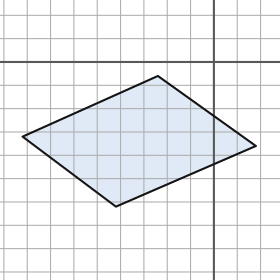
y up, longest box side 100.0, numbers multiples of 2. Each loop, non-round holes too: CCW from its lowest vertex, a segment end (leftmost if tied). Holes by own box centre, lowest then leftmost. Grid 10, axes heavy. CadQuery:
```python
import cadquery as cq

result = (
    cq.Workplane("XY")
    .moveTo(-42.0, -62.0)
    .lineTo(18.0, -36.0)
    .lineTo(-24.0, -6.0)
    .lineTo(-82.0, -32.0)
    .close()
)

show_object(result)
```